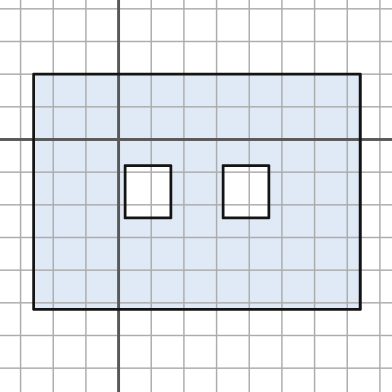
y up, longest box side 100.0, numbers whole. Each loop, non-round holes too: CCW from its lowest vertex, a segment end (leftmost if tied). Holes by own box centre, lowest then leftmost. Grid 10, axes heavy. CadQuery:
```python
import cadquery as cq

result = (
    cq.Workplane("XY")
    .moveTo(-26.0, -52.0)
    .lineTo(74.0, -52.0)
    .lineTo(74.0, 20.0)
    .lineTo(-26.0, 20.0)
    .close()
    .moveTo(2.0, -24.0)
    .lineTo(16.0, -24.0)
    .lineTo(16.0, -8.0)
    .lineTo(2.0, -8.0)
    .close()
    .moveTo(32.0, -24.0)
    .lineTo(46.0, -24.0)
    .lineTo(46.0, -8.0)
    .lineTo(32.0, -8.0)
    .close()
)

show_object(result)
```